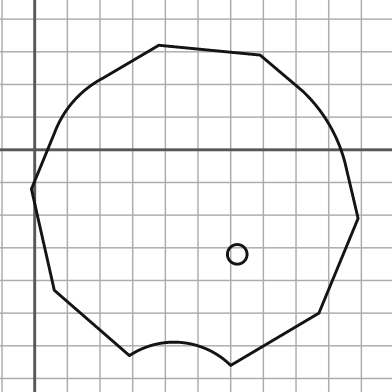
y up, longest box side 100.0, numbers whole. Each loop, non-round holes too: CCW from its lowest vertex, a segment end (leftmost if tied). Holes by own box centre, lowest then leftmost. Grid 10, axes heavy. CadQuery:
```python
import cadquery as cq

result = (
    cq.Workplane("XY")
    .moveTo(60.0, -66.0)
    .lineTo(87.0, -50.0)
    .lineTo(99.0, -21.0)
    .lineTo(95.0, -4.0)
    .threePointArc((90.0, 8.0), (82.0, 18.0))
    .lineTo(69.0, 29.0)
    .lineTo(38.0, 32.0)
    .lineTo(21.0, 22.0)
    .threePointArc((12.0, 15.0), (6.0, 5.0))
    .lineTo(-1.0, -12.0)
    .lineTo(6.0, -43.0)
    .lineTo(29.0, -63.0)
    .threePointArc((45.0, -59.0), (60.0, -66.0))
    .close()
    .moveTo(62.0, -32.0)
    .circle(3.0)
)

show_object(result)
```